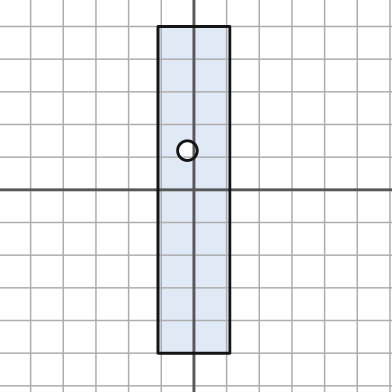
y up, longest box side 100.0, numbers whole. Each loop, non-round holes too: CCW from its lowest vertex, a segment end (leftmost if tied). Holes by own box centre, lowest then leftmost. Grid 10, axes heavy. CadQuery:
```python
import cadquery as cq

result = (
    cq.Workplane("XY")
    .moveTo(-11.0, -50.0)
    .lineTo(11.0, -50.0)
    .lineTo(11.0, 50.0)
    .lineTo(-11.0, 50.0)
    .close()
    .moveTo(-2.0, 12.0)
    .circle(3.0)
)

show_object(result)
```